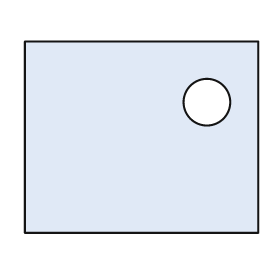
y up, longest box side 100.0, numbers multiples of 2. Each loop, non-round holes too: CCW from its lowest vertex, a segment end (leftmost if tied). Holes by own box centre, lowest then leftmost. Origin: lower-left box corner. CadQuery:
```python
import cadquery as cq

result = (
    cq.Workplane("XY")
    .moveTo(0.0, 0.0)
    .lineTo(100.0, 0.0)
    .lineTo(100.0, 82.0)
    .lineTo(0.0, 82.0)
    .close()
    .moveTo(78.0, 56.0)
    .circle(10.0)
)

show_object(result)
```